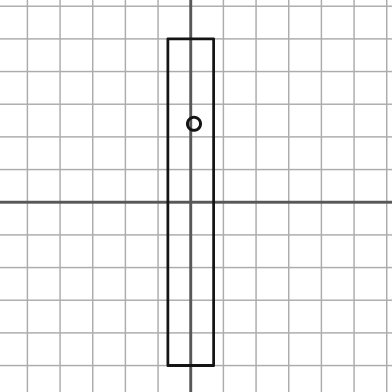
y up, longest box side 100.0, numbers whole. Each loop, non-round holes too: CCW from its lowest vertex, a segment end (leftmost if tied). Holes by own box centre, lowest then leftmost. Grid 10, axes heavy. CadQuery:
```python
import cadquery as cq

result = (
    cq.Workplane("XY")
    .moveTo(-7.0, -50.0)
    .lineTo(7.0, -50.0)
    .lineTo(7.0, 50.0)
    .lineTo(-7.0, 50.0)
    .close()
    .moveTo(1.0, 24.0)
    .circle(2.0)
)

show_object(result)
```